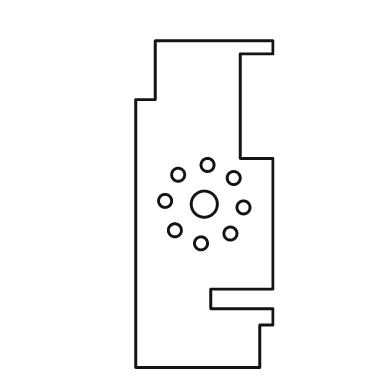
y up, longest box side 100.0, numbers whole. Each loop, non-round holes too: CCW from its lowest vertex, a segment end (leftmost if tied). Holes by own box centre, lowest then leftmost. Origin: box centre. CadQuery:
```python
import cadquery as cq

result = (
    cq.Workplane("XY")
    .moveTo(-21.0, -50.0)
    .lineTo(17.0, -50.0)
    .lineTo(17.0, -37.0)
    .lineTo(21.0, -37.0)
    .lineTo(21.0, -32.0)
    .lineTo(2.0, -32.0)
    .lineTo(2.0, -26.0)
    .lineTo(21.0, -26.0)
    .lineTo(21.0, 14.0)
    .lineTo(11.0, 14.0)
    .lineTo(11.0, 46.0)
    .lineTo(21.0, 46.0)
    .lineTo(21.0, 50.0)
    .lineTo(-15.0, 50.0)
    .lineTo(-15.0, 32.0)
    .lineTo(-21.0, 32.0)
    .close()
    .moveTo(-1.0, -12.0)
    .circle(2.0)
    .moveTo(8.0, -9.0)
    .circle(2.0)
    .moveTo(-9.0, -8.0)
    .circle(2.0)
    .moveTo(12.0, -1.0)
    .circle(2.0)
    .moveTo(0.0, 0.0)
    .circle(4.0)
    .moveTo(-12.0, 1.0)
    .circle(2.0)
    .moveTo(9.0, 8.0)
    .circle(2.0)
    .moveTo(-8.0, 9.0)
    .circle(2.0)
    .moveTo(1.0, 12.0)
    .circle(2.0)
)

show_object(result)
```